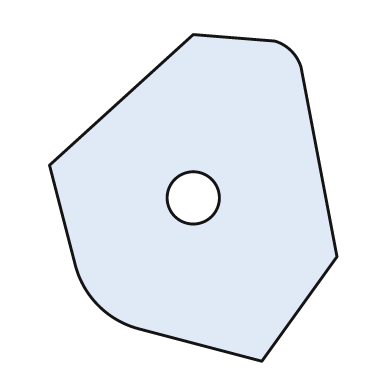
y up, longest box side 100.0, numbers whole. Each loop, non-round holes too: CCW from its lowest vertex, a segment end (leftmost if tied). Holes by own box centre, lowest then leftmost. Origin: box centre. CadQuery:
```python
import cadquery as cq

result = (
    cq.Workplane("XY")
    .moveTo(21.0, -50.0)
    .lineTo(44.0, -18.0)
    .lineTo(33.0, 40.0)
    .threePointArc((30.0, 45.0), (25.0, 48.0))
    .lineTo(0.0, 50.0)
    .lineTo(-44.0, 10.0)
    .lineTo(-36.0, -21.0)
    .threePointArc((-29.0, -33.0), (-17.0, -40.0))
    .close()
    .moveTo(0.0, 0.0)
    .circle(8.0)
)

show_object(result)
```